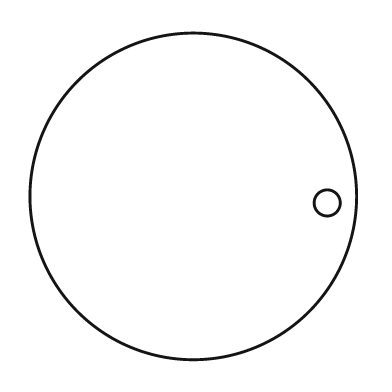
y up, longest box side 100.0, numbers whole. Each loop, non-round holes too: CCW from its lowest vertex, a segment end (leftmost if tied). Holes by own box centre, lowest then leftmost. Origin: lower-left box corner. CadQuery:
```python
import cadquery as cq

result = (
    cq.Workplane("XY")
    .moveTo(50.0, 50.0)
    .circle(50.0)
    .moveTo(91.0, 48.0)
    .circle(4.0)
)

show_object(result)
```